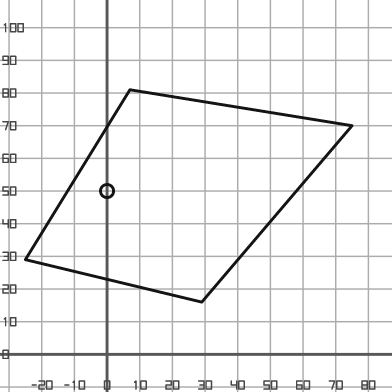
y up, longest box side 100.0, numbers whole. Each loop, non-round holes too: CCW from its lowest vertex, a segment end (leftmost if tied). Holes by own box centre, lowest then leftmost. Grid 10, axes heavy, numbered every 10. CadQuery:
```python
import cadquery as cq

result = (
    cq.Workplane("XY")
    .moveTo(29.0, 16.0)
    .lineTo(75.0, 70.0)
    .lineTo(7.0, 81.0)
    .lineTo(-25.0, 29.0)
    .close()
    .moveTo(0.0, 50.0)
    .circle(2.0)
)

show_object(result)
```